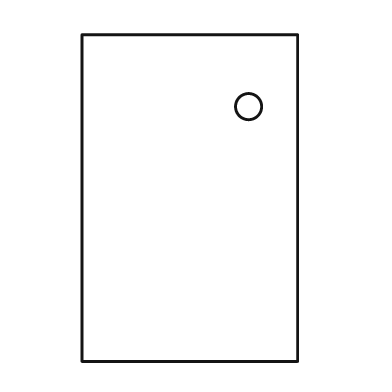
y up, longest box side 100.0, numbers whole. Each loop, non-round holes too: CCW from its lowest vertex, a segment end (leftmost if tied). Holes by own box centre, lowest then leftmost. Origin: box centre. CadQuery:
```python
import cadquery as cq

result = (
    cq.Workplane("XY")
    .moveTo(-33.0, -50.0)
    .lineTo(33.0, -50.0)
    .lineTo(33.0, 50.0)
    .lineTo(-33.0, 50.0)
    .close()
    .moveTo(18.0, 28.0)
    .circle(4.0)
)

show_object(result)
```